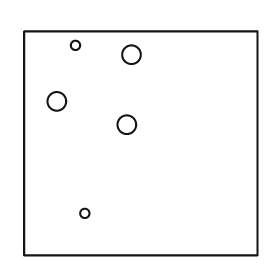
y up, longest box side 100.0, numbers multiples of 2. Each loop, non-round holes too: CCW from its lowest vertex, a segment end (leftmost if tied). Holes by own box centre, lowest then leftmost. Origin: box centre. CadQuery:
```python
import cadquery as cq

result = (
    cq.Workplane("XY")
    .moveTo(-50.0, -48.0)
    .lineTo(50.0, -48.0)
    .lineTo(50.0, 48.0)
    .lineTo(-50.0, 48.0)
    .close()
    .moveTo(-24.0, -30.0)
    .circle(2.0)
    .moveTo(-6.0, 8.0)
    .circle(4.0)
    .moveTo(-36.0, 18.0)
    .circle(4.0)
    .moveTo(-4.0, 38.0)
    .circle(4.0)
    .moveTo(-28.0, 42.0)
    .circle(2.0)
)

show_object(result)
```